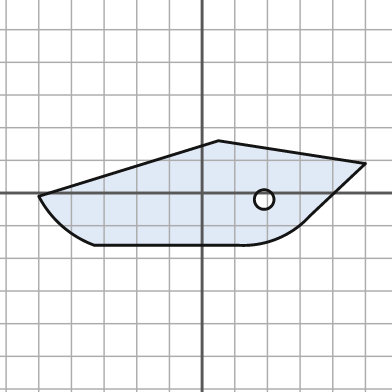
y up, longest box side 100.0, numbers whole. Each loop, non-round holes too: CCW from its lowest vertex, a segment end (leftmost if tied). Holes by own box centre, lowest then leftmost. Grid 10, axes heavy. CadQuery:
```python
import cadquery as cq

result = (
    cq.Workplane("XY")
    .moveTo(-33.0, -16.0)
    .lineTo(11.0, -16.0)
    .threePointArc((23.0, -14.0), (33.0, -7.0))
    .lineTo(50.0, 9.0)
    .lineTo(5.0, 16.0)
    .lineTo(-50.0, -1.0)
    .threePointArc((-43.0, -10.0), (-33.0, -16.0))
    .close()
    .moveTo(19.0, -2.0)
    .circle(3.0)
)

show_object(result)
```